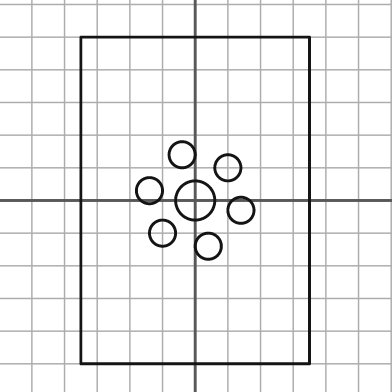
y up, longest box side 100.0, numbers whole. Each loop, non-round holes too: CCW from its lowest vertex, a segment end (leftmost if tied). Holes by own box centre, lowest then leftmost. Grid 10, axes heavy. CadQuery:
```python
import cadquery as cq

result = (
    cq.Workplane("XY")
    .moveTo(-35.0, -50.0)
    .lineTo(35.0, -50.0)
    .lineTo(35.0, 50.0)
    .lineTo(-35.0, 50.0)
    .close()
    .moveTo(4.0, -14.0)
    .circle(4.0)
    .moveTo(-10.0, -10.0)
    .circle(4.0)
    .moveTo(14.0, -3.0)
    .circle(4.0)
    .moveTo(0.0, 0.0)
    .circle(6.0)
    .moveTo(-14.0, 3.0)
    .circle(4.0)
    .moveTo(10.0, 10.0)
    .circle(4.0)
    .moveTo(-4.0, 14.0)
    .circle(4.0)
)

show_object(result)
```